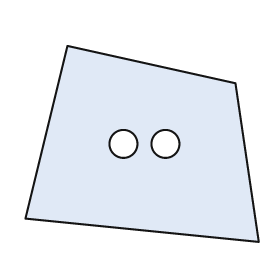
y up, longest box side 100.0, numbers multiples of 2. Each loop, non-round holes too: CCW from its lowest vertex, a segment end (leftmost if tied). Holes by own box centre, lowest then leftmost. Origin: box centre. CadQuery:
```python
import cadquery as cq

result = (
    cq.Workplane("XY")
    .moveTo(50.0, -42.0)
    .lineTo(40.0, 26.0)
    .lineTo(-32.0, 42.0)
    .lineTo(-50.0, -32.0)
    .close()
    .moveTo(-8.0, 0.0)
    .circle(6.0)
    .moveTo(10.0, 0.0)
    .circle(6.0)
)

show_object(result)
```